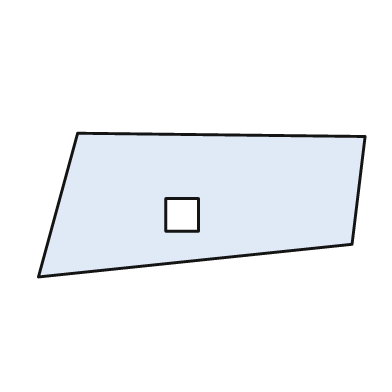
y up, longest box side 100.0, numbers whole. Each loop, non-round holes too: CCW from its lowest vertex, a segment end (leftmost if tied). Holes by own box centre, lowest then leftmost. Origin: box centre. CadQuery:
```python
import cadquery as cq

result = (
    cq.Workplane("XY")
    .moveTo(-50.0, -22.0)
    .lineTo(46.0, -12.0)
    .lineTo(50.0, 21.0)
    .lineTo(-38.0, 22.0)
    .close()
    .moveTo(-11.0, -8.0)
    .lineTo(-1.0, -8.0)
    .lineTo(-1.0, 2.0)
    .lineTo(-11.0, 2.0)
    .close()
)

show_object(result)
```